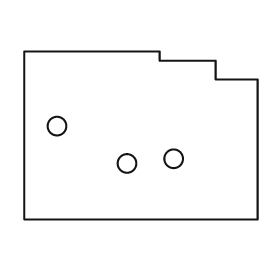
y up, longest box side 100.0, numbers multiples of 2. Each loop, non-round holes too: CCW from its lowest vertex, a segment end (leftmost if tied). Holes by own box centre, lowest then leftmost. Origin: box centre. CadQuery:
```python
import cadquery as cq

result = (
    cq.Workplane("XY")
    .moveTo(-50.0, -36.0)
    .lineTo(50.0, -36.0)
    .lineTo(50.0, 24.0)
    .lineTo(32.0, 24.0)
    .lineTo(32.0, 32.0)
    .lineTo(8.0, 32.0)
    .lineTo(8.0, 36.0)
    .lineTo(-50.0, 36.0)
    .close()
    .moveTo(-6.0, -12.0)
    .circle(4.0)
    .moveTo(14.0, -10.0)
    .circle(4.0)
    .moveTo(-36.0, 4.0)
    .circle(4.0)
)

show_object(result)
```